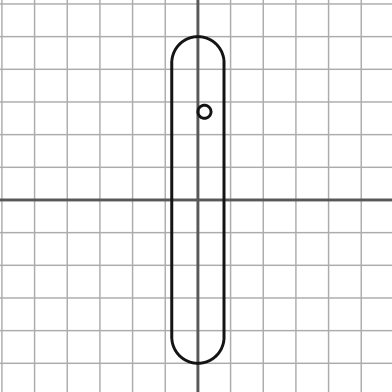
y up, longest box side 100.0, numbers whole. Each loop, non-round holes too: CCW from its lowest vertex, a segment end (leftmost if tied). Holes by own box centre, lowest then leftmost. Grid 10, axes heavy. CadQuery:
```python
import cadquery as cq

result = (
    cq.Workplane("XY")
    .moveTo(-8.0, -42.0)
    .threePointArc((0.0, -50.0), (8.0, -42.0))
    .lineTo(8.0, 42.0)
    .threePointArc((0.0, 50.0), (-8.0, 42.0))
    .close()
    .moveTo(2.0, 27.0)
    .circle(2.0)
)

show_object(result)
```